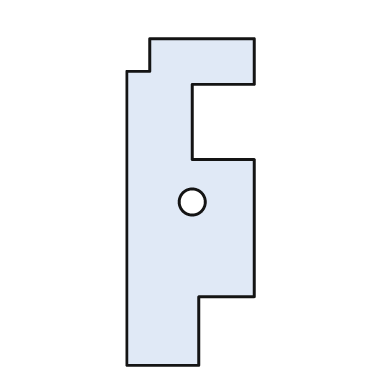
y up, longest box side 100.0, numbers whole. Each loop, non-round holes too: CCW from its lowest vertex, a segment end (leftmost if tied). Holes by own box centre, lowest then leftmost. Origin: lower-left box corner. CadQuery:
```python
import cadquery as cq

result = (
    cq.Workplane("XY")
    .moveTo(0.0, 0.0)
    .lineTo(22.0, 0.0)
    .lineTo(22.0, 21.0)
    .lineTo(39.0, 21.0)
    .lineTo(39.0, 63.0)
    .lineTo(20.0, 63.0)
    .lineTo(20.0, 86.0)
    .lineTo(39.0, 86.0)
    .lineTo(39.0, 100.0)
    .lineTo(7.0, 100.0)
    .lineTo(7.0, 90.0)
    .lineTo(0.0, 90.0)
    .close()
    .moveTo(20.0, 50.0)
    .circle(4.0)
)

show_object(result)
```